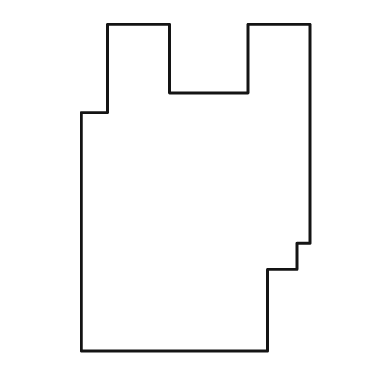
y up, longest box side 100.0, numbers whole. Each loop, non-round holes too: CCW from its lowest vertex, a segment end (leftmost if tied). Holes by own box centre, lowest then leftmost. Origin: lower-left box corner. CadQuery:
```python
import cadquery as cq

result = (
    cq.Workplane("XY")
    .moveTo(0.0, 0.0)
    .lineTo(57.0, 0.0)
    .lineTo(57.0, 25.0)
    .lineTo(66.0, 25.0)
    .lineTo(66.0, 33.0)
    .lineTo(70.0, 33.0)
    .lineTo(70.0, 100.0)
    .lineTo(51.0, 100.0)
    .lineTo(51.0, 79.0)
    .lineTo(27.0, 79.0)
    .lineTo(27.0, 100.0)
    .lineTo(8.0, 100.0)
    .lineTo(8.0, 73.0)
    .lineTo(0.0, 73.0)
    .close()
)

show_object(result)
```